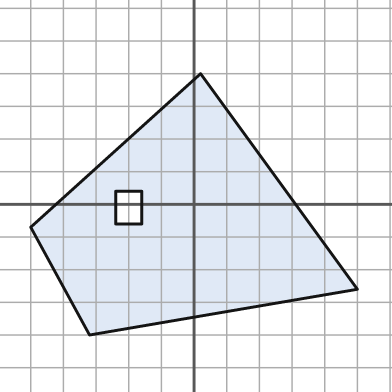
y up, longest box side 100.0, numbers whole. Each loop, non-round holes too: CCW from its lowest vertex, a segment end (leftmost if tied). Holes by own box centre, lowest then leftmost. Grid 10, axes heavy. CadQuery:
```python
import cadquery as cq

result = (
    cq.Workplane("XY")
    .moveTo(-32.0, -40.0)
    .lineTo(50.0, -26.0)
    .lineTo(2.0, 40.0)
    .lineTo(-50.0, -7.0)
    .close()
    .moveTo(-24.0, -6.0)
    .lineTo(-16.0, -6.0)
    .lineTo(-16.0, 4.0)
    .lineTo(-24.0, 4.0)
    .close()
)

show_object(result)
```